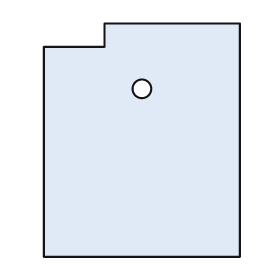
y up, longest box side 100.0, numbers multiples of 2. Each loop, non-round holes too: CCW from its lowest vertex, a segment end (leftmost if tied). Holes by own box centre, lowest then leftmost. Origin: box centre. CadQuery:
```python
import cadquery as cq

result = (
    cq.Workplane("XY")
    .moveTo(-42.0, -50.0)
    .lineTo(42.0, -50.0)
    .lineTo(42.0, 50.0)
    .lineTo(-16.0, 50.0)
    .lineTo(-16.0, 40.0)
    .lineTo(-42.0, 40.0)
    .close()
    .moveTo(0.0, 22.0)
    .circle(4.0)
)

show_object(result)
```